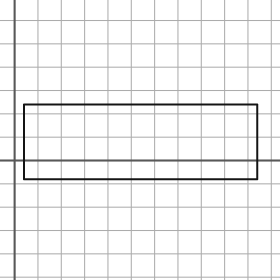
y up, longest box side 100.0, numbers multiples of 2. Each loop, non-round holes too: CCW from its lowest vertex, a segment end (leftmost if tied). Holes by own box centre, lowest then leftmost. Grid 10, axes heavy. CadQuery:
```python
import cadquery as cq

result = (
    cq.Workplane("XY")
    .moveTo(4.0, -8.0)
    .lineTo(104.0, -8.0)
    .lineTo(104.0, 24.0)
    .lineTo(4.0, 24.0)
    .close()
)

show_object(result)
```